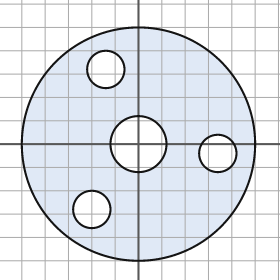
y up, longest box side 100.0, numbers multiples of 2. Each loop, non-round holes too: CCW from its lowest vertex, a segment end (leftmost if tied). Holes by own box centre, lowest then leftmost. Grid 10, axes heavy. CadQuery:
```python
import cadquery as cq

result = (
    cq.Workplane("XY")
    .moveTo(0.0, 0.0)
    .circle(50.0)
    .moveTo(-20.0, -28.0)
    .circle(8.0)
    .moveTo(34.0, -4.0)
    .circle(8.0)
    .moveTo(0.0, 0.0)
    .circle(12.0)
    .moveTo(-14.0, 32.0)
    .circle(8.0)
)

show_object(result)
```